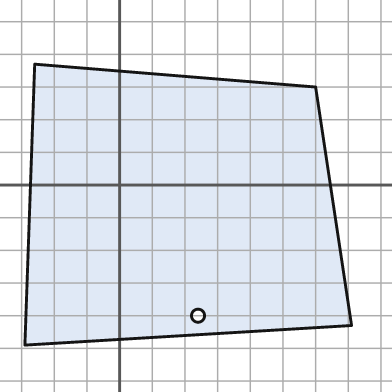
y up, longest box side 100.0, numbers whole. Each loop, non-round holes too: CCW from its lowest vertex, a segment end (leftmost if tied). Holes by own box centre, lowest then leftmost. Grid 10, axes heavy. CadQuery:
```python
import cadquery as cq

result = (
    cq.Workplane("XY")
    .moveTo(-29.0, -49.0)
    .lineTo(71.0, -43.0)
    .lineTo(60.0, 30.0)
    .lineTo(-26.0, 37.0)
    .close()
    .moveTo(24.0, -40.0)
    .circle(2.0)
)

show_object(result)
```